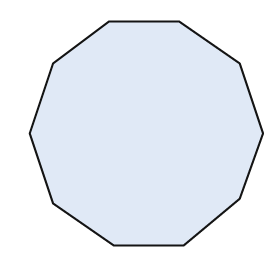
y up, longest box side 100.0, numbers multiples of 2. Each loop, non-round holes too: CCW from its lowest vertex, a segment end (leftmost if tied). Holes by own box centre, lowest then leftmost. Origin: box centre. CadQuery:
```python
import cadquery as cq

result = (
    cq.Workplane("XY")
    .moveTo(-14.0, -48.0)
    .lineTo(16.0, -48.0)
    .lineTo(40.0, -28.0)
    .lineTo(50.0, 0.0)
    .lineTo(40.0, 30.0)
    .lineTo(14.0, 48.0)
    .lineTo(-16.0, 48.0)
    .lineTo(-40.0, 30.0)
    .lineTo(-50.0, 0.0)
    .lineTo(-40.0, -30.0)
    .close()
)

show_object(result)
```